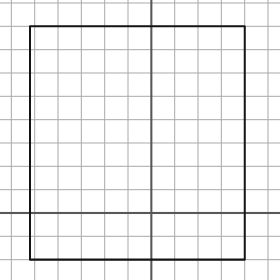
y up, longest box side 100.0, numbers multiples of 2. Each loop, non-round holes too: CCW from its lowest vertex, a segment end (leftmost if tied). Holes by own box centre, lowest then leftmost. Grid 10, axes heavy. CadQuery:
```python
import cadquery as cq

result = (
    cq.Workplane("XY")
    .moveTo(-52.0, -20.0)
    .lineTo(40.0, -20.0)
    .lineTo(40.0, 80.0)
    .lineTo(-52.0, 80.0)
    .close()
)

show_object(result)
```